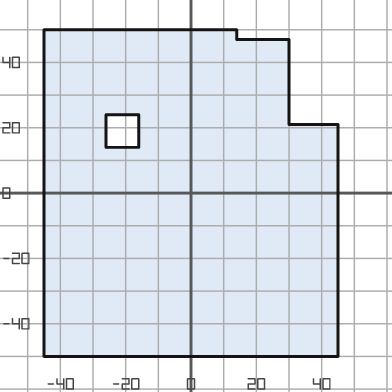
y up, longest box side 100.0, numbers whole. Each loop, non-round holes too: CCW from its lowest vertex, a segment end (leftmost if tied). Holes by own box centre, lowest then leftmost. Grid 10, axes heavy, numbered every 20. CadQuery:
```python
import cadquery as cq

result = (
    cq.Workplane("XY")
    .moveTo(-45.0, -50.0)
    .lineTo(45.0, -50.0)
    .lineTo(45.0, 21.0)
    .lineTo(30.0, 21.0)
    .lineTo(30.0, 47.0)
    .lineTo(14.0, 47.0)
    .lineTo(14.0, 50.0)
    .lineTo(-45.0, 50.0)
    .close()
    .moveTo(-26.0, 14.0)
    .lineTo(-16.0, 14.0)
    .lineTo(-16.0, 24.0)
    .lineTo(-26.0, 24.0)
    .close()
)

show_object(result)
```